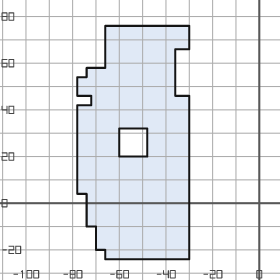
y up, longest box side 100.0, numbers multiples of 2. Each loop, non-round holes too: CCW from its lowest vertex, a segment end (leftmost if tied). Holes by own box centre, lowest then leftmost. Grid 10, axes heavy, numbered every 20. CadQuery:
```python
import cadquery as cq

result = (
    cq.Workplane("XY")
    .moveTo(-66.0, -24.0)
    .lineTo(-30.0, -24.0)
    .lineTo(-30.0, 46.0)
    .lineTo(-36.0, 46.0)
    .lineTo(-36.0, 66.0)
    .lineTo(-30.0, 66.0)
    .lineTo(-30.0, 76.0)
    .lineTo(-66.0, 76.0)
    .lineTo(-66.0, 58.0)
    .lineTo(-74.0, 58.0)
    .lineTo(-74.0, 54.0)
    .lineTo(-78.0, 54.0)
    .lineTo(-78.0, 46.0)
    .lineTo(-72.0, 46.0)
    .lineTo(-72.0, 42.0)
    .lineTo(-78.0, 42.0)
    .lineTo(-78.0, 4.0)
    .lineTo(-74.0, 4.0)
    .lineTo(-74.0, -10.0)
    .lineTo(-70.0, -10.0)
    .lineTo(-70.0, -20.0)
    .lineTo(-66.0, -20.0)
    .close()
    .moveTo(-60.0, 20.0)
    .lineTo(-48.0, 20.0)
    .lineTo(-48.0, 32.0)
    .lineTo(-60.0, 32.0)
    .close()
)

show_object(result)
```